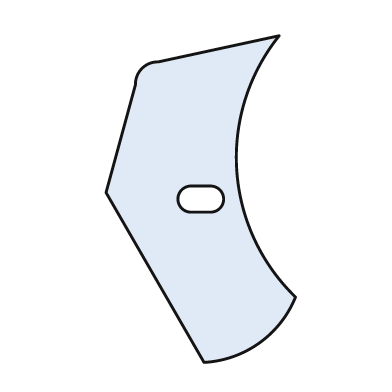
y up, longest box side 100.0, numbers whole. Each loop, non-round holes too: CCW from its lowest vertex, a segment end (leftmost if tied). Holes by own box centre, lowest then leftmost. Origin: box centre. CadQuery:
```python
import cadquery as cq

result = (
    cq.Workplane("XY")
    .moveTo(1.0, -50.0)
    .threePointArc((18.0, -44.0), (29.0, -30.0))
    .threePointArc((11.0, 9.0), (24.0, 50.0))
    .lineTo(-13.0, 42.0)
    .threePointArc((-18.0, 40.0), (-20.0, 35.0))
    .lineTo(-29.0, 2.0)
    .close()
    .moveTo(-3.0, -4.0)
    .lineTo(3.0, -4.0)
    .threePointArc((7.0, 0.0), (3.0, 4.0))
    .lineTo(-3.0, 4.0)
    .threePointArc((-7.0, 0.0), (-3.0, -4.0))
    .close()
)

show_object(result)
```